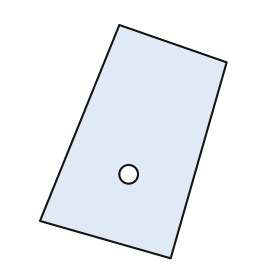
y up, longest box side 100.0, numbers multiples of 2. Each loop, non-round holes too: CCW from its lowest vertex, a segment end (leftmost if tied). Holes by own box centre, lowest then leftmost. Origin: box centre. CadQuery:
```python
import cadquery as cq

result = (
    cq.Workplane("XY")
    .moveTo(16.0, -50.0)
    .lineTo(40.0, 34.0)
    .lineTo(-6.0, 50.0)
    .lineTo(-40.0, -34.0)
    .close()
    .moveTo(-2.0, -14.0)
    .circle(4.0)
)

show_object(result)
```